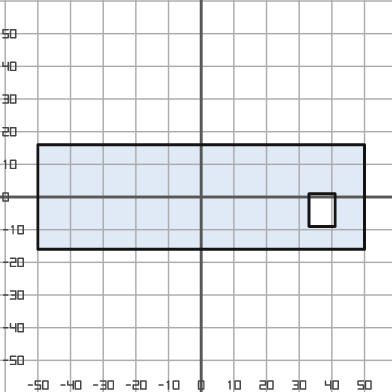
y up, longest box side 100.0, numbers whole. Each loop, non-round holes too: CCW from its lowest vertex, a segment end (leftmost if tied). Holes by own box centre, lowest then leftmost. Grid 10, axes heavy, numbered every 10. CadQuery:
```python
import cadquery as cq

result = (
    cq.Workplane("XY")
    .moveTo(-50.0, -16.0)
    .lineTo(50.0, -16.0)
    .lineTo(50.0, 16.0)
    .lineTo(-50.0, 16.0)
    .close()
    .moveTo(33.0, -9.0)
    .lineTo(41.0, -9.0)
    .lineTo(41.0, 1.0)
    .lineTo(33.0, 1.0)
    .close()
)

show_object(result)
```